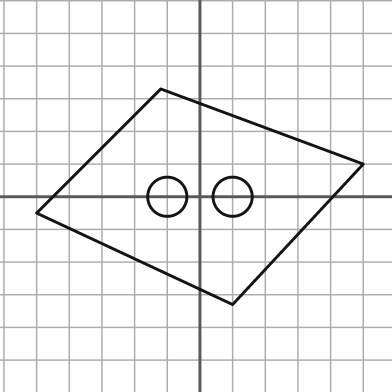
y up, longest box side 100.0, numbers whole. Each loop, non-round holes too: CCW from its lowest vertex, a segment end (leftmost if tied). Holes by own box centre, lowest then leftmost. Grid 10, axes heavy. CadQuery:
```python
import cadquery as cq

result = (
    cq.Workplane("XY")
    .moveTo(10.0, -33.0)
    .lineTo(50.0, 10.0)
    .lineTo(-12.0, 33.0)
    .lineTo(-50.0, -5.0)
    .close()
    .moveTo(-10.0, 0.0)
    .circle(6.0)
    .moveTo(10.0, 0.0)
    .circle(6.0)
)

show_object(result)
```